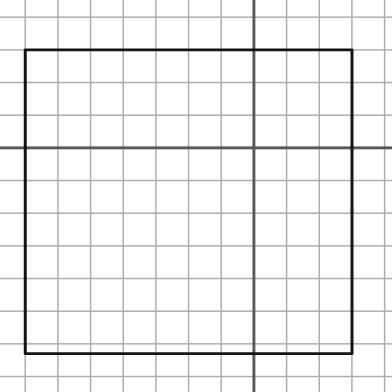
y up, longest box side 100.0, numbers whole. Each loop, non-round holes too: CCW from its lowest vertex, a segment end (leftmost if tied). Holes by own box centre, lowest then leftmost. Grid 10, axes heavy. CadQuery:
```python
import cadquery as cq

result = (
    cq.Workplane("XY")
    .moveTo(-70.0, -63.0)
    .lineTo(30.0, -63.0)
    .lineTo(30.0, 30.0)
    .lineTo(-70.0, 30.0)
    .close()
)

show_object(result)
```